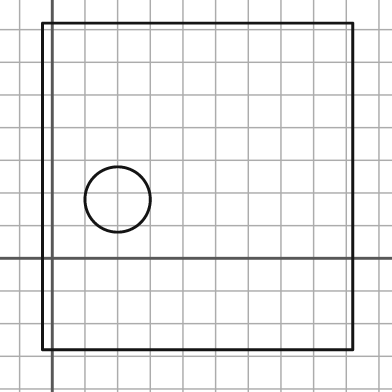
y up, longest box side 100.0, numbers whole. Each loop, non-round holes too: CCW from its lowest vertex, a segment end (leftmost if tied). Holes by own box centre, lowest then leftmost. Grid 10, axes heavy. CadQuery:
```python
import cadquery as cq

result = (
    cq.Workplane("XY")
    .moveTo(-3.0, -28.0)
    .lineTo(92.0, -28.0)
    .lineTo(92.0, 72.0)
    .lineTo(-3.0, 72.0)
    .close()
    .moveTo(20.0, 18.0)
    .circle(10.0)
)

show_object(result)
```